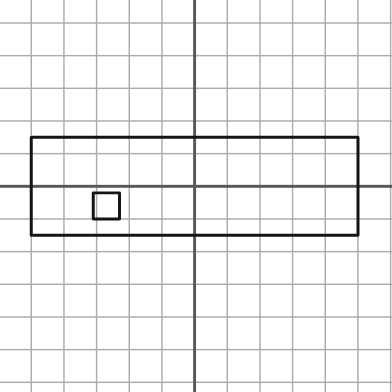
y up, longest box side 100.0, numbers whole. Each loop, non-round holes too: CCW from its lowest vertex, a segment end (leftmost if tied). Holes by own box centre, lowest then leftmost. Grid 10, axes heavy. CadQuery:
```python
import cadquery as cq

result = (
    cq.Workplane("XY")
    .moveTo(-50.0, -15.0)
    .lineTo(50.0, -15.0)
    .lineTo(50.0, 15.0)
    .lineTo(-50.0, 15.0)
    .close()
    .moveTo(-31.0, -10.0)
    .lineTo(-23.0, -10.0)
    .lineTo(-23.0, -2.0)
    .lineTo(-31.0, -2.0)
    .close()
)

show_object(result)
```